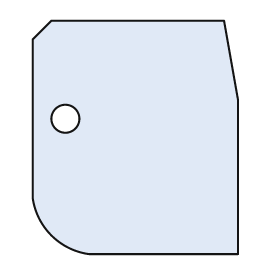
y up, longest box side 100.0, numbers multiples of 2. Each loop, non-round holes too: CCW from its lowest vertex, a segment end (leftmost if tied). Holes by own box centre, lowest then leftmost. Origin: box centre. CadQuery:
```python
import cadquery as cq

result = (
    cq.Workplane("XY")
    .moveTo(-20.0, -50.0)
    .lineTo(44.0, -50.0)
    .lineTo(44.0, 16.0)
    .lineTo(38.0, 50.0)
    .lineTo(-36.0, 50.0)
    .lineTo(-44.0, 42.0)
    .lineTo(-44.0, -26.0)
    .threePointArc((-36.0, -42.0), (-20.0, -50.0))
    .close()
    .moveTo(-30.0, 8.0)
    .circle(6.0)
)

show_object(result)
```